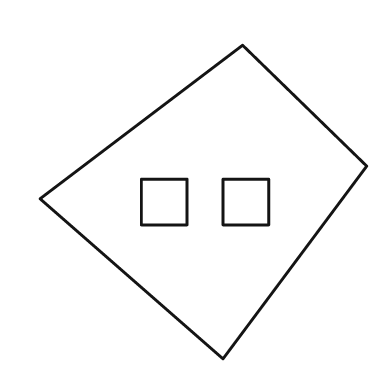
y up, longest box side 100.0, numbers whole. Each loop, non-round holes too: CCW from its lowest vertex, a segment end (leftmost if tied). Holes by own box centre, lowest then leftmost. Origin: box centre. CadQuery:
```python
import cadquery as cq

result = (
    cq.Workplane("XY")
    .moveTo(6.0, -48.0)
    .lineTo(50.0, 11.0)
    .lineTo(12.0, 48.0)
    .lineTo(-50.0, 1.0)
    .close()
    .moveTo(-19.0, -7.0)
    .lineTo(-5.0, -7.0)
    .lineTo(-5.0, 7.0)
    .lineTo(-19.0, 7.0)
    .close()
    .moveTo(6.0, -7.0)
    .lineTo(20.0, -7.0)
    .lineTo(20.0, 7.0)
    .lineTo(6.0, 7.0)
    .close()
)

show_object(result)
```